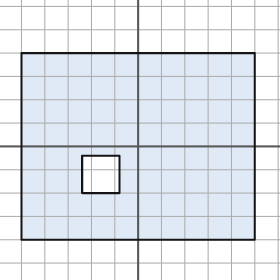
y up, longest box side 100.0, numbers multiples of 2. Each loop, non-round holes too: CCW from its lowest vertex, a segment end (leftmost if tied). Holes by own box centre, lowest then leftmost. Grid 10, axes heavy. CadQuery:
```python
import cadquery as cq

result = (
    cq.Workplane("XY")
    .moveTo(-50.0, -40.0)
    .lineTo(50.0, -40.0)
    .lineTo(50.0, 40.0)
    .lineTo(-50.0, 40.0)
    .close()
    .moveTo(-24.0, -20.0)
    .lineTo(-8.0, -20.0)
    .lineTo(-8.0, -4.0)
    .lineTo(-24.0, -4.0)
    .close()
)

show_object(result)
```